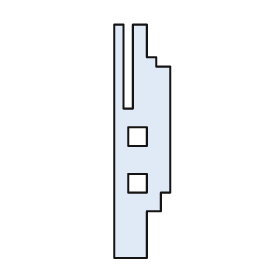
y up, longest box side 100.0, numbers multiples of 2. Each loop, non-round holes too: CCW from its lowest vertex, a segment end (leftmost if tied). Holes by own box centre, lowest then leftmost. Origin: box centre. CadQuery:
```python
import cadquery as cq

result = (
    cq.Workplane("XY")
    .moveTo(-12.0, -50.0)
    .lineTo(2.0, -50.0)
    .lineTo(2.0, -30.0)
    .lineTo(8.0, -30.0)
    .lineTo(8.0, -22.0)
    .lineTo(12.0, -22.0)
    .lineTo(12.0, 32.0)
    .lineTo(6.0, 32.0)
    .lineTo(6.0, 36.0)
    .lineTo(2.0, 36.0)
    .lineTo(2.0, 50.0)
    .lineTo(-4.0, 50.0)
    .lineTo(-4.0, 14.0)
    .lineTo(-8.0, 14.0)
    .lineTo(-8.0, 50.0)
    .lineTo(-12.0, 50.0)
    .close()
    .moveTo(-6.0, -22.0)
    .lineTo(2.0, -22.0)
    .lineTo(2.0, -14.0)
    .lineTo(-6.0, -14.0)
    .close()
    .moveTo(-6.0, -2.0)
    .lineTo(2.0, -2.0)
    .lineTo(2.0, 6.0)
    .lineTo(-6.0, 6.0)
    .close()
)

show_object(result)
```